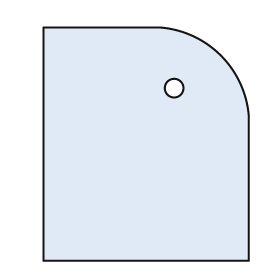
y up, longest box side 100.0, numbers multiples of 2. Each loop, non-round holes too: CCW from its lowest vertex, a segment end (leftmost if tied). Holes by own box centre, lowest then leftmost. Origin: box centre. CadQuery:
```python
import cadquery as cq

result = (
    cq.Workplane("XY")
    .moveTo(-44.0, -50.0)
    .lineTo(44.0, -50.0)
    .lineTo(44.0, 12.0)
    .threePointArc((32.0, 38.0), (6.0, 50.0))
    .lineTo(-44.0, 50.0)
    .close()
    .moveTo(12.0, 24.0)
    .circle(4.0)
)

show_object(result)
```